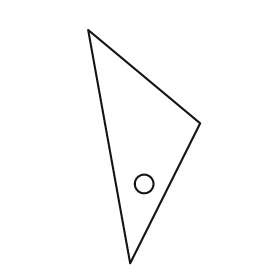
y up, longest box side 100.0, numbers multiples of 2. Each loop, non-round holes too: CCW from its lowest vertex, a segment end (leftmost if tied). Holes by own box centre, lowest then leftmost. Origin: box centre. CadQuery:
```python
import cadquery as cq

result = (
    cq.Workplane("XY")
    .moveTo(-6.0, -50.0)
    .lineTo(24.0, 10.0)
    .lineTo(-24.0, 50.0)
    .close()
    .moveTo(0.0, -16.0)
    .circle(4.0)
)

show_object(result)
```